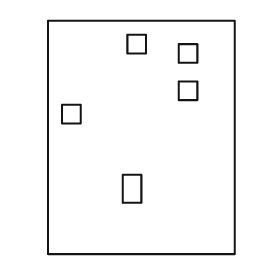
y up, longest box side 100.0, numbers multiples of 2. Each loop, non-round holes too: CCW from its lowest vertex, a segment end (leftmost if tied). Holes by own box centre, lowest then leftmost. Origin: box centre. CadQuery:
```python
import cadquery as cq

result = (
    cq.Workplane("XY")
    .moveTo(-40.0, -50.0)
    .lineTo(40.0, -50.0)
    .lineTo(40.0, 50.0)
    .lineTo(-40.0, 50.0)
    .close()
    .moveTo(-8.0, -28.0)
    .lineTo(0.0, -28.0)
    .lineTo(0.0, -16.0)
    .lineTo(-8.0, -16.0)
    .close()
    .moveTo(-34.0, 6.0)
    .lineTo(-26.0, 6.0)
    .lineTo(-26.0, 14.0)
    .lineTo(-34.0, 14.0)
    .close()
    .moveTo(16.0, 16.0)
    .lineTo(24.0, 16.0)
    .lineTo(24.0, 24.0)
    .lineTo(16.0, 24.0)
    .close()
    .moveTo(16.0, 32.0)
    .lineTo(24.0, 32.0)
    .lineTo(24.0, 40.0)
    .lineTo(16.0, 40.0)
    .close()
    .moveTo(-6.0, 36.0)
    .lineTo(2.0, 36.0)
    .lineTo(2.0, 44.0)
    .lineTo(-6.0, 44.0)
    .close()
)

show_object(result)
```